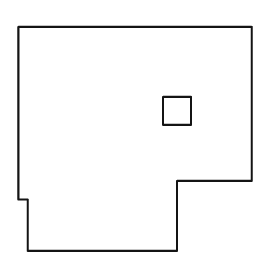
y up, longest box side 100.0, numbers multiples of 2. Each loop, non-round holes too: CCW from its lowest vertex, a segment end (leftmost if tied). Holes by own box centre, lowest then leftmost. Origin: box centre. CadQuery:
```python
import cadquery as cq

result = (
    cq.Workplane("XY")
    .moveTo(-46.0, -48.0)
    .lineTo(18.0, -48.0)
    .lineTo(18.0, -18.0)
    .lineTo(50.0, -18.0)
    .lineTo(50.0, 48.0)
    .lineTo(-50.0, 48.0)
    .lineTo(-50.0, -26.0)
    .lineTo(-46.0, -26.0)
    .close()
    .moveTo(12.0, 6.0)
    .lineTo(24.0, 6.0)
    .lineTo(24.0, 18.0)
    .lineTo(12.0, 18.0)
    .close()
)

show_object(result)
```